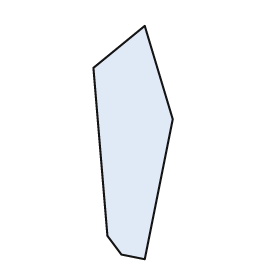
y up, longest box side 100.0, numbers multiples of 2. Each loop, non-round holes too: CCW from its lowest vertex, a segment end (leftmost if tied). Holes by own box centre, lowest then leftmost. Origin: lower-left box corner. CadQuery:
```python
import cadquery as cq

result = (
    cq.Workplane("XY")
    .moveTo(22.0, 0.0)
    .lineTo(34.0, 60.0)
    .lineTo(22.0, 100.0)
    .lineTo(0.0, 82.0)
    .lineTo(6.0, 10.0)
    .lineTo(12.0, 2.0)
    .close()
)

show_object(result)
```